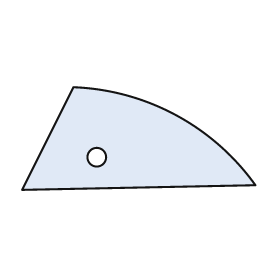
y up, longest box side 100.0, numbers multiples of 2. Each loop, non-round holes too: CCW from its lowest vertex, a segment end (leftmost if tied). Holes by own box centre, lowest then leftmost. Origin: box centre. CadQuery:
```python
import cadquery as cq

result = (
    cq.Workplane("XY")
    .moveTo(-50.0, -22.0)
    .lineTo(50.0, -20.0)
    .threePointArc((16.0, 10.0), (-28.0, 22.0))
    .close()
    .moveTo(-18.0, -8.0)
    .circle(4.0)
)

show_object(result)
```